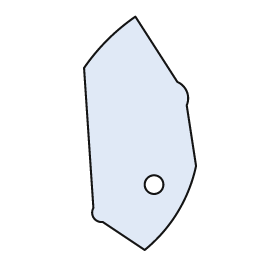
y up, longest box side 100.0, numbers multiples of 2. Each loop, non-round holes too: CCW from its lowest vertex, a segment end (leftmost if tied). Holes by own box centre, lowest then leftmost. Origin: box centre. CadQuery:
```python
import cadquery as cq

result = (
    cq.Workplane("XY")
    .moveTo(2.0, -50.0)
    .threePointArc((16.0, -34.0), (24.0, -14.0))
    .lineTo(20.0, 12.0)
    .threePointArc((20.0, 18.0), (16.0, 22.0))
    .lineTo(-2.0, 50.0)
    .threePointArc((-14.0, 40.0), (-24.0, 28.0))
    .lineTo(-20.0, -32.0)
    .threePointArc((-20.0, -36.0), (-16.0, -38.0))
    .close()
    .moveTo(6.0, -22.0)
    .circle(4.0)
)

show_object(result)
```